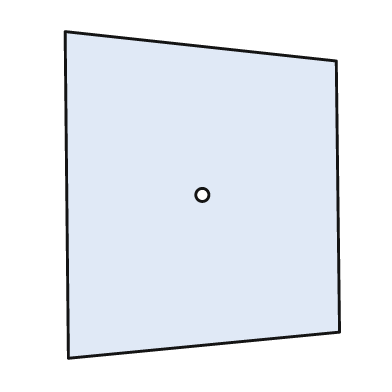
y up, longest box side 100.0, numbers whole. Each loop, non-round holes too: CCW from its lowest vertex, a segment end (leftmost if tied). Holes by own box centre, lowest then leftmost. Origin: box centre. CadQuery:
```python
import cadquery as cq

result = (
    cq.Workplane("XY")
    .moveTo(-41.0, -50.0)
    .lineTo(42.0, -42.0)
    .lineTo(41.0, 41.0)
    .lineTo(-42.0, 50.0)
    .close()
    .moveTo(0.0, 0.0)
    .circle(2.0)
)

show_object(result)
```